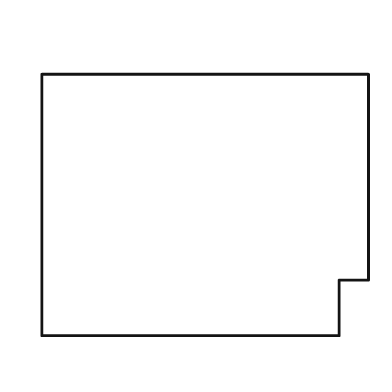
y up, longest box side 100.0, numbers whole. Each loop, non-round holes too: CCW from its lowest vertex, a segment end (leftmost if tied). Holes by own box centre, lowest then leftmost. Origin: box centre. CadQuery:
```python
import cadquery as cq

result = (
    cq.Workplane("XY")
    .moveTo(-50.0, -40.0)
    .lineTo(41.0, -40.0)
    .lineTo(41.0, -23.0)
    .lineTo(50.0, -23.0)
    .lineTo(50.0, 40.0)
    .lineTo(-50.0, 40.0)
    .close()
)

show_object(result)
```